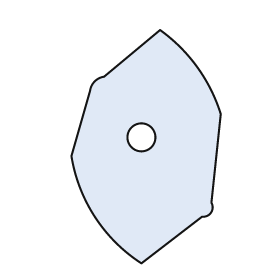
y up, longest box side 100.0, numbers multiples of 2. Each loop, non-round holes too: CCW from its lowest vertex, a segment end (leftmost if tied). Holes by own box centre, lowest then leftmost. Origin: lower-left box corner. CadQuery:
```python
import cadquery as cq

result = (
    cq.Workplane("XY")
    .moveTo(30.0, 0.0)
    .lineTo(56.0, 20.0)
    .threePointArc((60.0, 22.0), (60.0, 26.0))
    .lineTo(64.0, 64.0)
    .threePointArc((54.0, 84.0), (38.0, 100.0))
    .lineTo(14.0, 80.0)
    .threePointArc((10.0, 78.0), (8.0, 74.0))
    .lineTo(0.0, 46.0)
    .threePointArc((10.0, 20.0), (30.0, 0.0))
    .close()
    .moveTo(30.0, 54.0)
    .circle(6.0)
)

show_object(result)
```